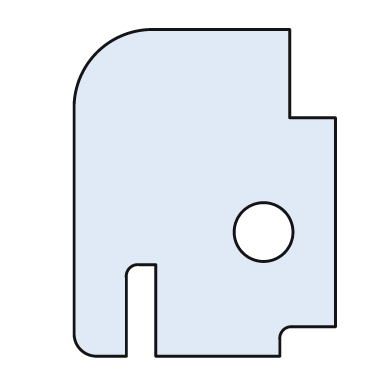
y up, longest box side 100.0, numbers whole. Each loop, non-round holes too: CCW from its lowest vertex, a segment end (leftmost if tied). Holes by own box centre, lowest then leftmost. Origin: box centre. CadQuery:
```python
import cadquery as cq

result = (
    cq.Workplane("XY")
    .moveTo(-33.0, -50.0)
    .lineTo(-24.0, -50.0)
    .lineTo(-24.0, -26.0)
    .threePointArc((-23.0, -23.0), (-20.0, -22.0))
    .lineTo(-15.0, -22.0)
    .lineTo(-15.0, -50.0)
    .lineTo(23.0, -50.0)
    .lineTo(23.0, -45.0)
    .threePointArc((24.0, -42.0), (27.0, -41.0))
    .lineTo(40.0, -41.0)
    .lineTo(40.0, 23.0)
    .lineTo(26.0, 23.0)
    .lineTo(26.0, 50.0)
    .lineTo(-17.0, 50.0)
    .threePointArc((-33.0, 43.0), (-40.0, 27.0))
    .lineTo(-40.0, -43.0)
    .threePointArc((-38.0, -48.0), (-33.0, -50.0))
    .close()
    .moveTo(18.0, -12.0)
    .circle(9.0)
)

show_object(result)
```